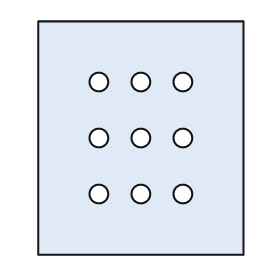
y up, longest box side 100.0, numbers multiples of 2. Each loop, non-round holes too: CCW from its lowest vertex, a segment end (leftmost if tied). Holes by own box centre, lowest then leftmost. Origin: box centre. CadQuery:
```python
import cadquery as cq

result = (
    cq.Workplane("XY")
    .moveTo(-44.0, -50.0)
    .lineTo(44.0, -50.0)
    .lineTo(44.0, 50.0)
    .lineTo(-44.0, 50.0)
    .close()
    .moveTo(-18.0, -24.0)
    .circle(4.0)
    .moveTo(0.0, -24.0)
    .circle(4.0)
    .moveTo(18.0, -24.0)
    .circle(4.0)
    .moveTo(-18.0, 0.0)
    .circle(4.0)
    .moveTo(0.0, 0.0)
    .circle(4.0)
    .moveTo(18.0, 0.0)
    .circle(4.0)
    .moveTo(-18.0, 24.0)
    .circle(4.0)
    .moveTo(0.0, 24.0)
    .circle(4.0)
    .moveTo(18.0, 24.0)
    .circle(4.0)
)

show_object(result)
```